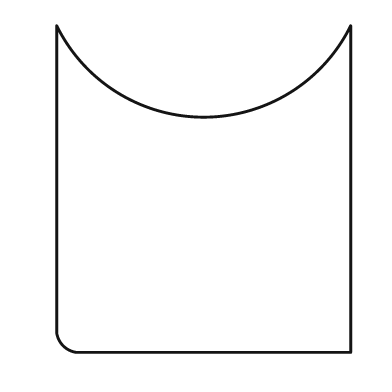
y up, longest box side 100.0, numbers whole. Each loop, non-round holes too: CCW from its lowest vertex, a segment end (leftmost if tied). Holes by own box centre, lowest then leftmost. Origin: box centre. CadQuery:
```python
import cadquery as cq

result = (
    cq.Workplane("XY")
    .moveTo(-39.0, -50.0)
    .lineTo(45.0, -50.0)
    .lineTo(45.0, 50.0)
    .threePointArc((0.0, 22.0), (-45.0, 50.0))
    .lineTo(-45.0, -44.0)
    .threePointArc((-43.0, -48.0), (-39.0, -50.0))
    .close()
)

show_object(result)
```